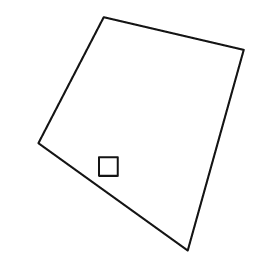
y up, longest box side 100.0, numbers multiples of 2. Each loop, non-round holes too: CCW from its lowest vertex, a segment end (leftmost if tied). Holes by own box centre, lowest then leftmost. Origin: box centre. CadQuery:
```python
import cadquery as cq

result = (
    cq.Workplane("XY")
    .moveTo(20.0, -50.0)
    .lineTo(44.0, 36.0)
    .lineTo(-16.0, 50.0)
    .lineTo(-44.0, -4.0)
    .close()
    .moveTo(-18.0, -18.0)
    .lineTo(-10.0, -18.0)
    .lineTo(-10.0, -10.0)
    .lineTo(-18.0, -10.0)
    .close()
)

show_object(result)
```